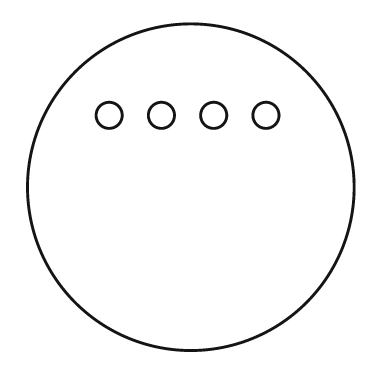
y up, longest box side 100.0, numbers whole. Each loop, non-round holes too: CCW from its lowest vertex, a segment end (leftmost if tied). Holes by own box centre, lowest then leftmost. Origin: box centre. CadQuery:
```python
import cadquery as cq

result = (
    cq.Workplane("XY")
    .moveTo(0.0, 0.0)
    .circle(50.0)
    .moveTo(-25.0, 22.0)
    .circle(4.0)
    .moveTo(-9.0, 22.0)
    .circle(4.0)
    .moveTo(7.0, 22.0)
    .circle(4.0)
    .moveTo(23.0, 22.0)
    .circle(4.0)
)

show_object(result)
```